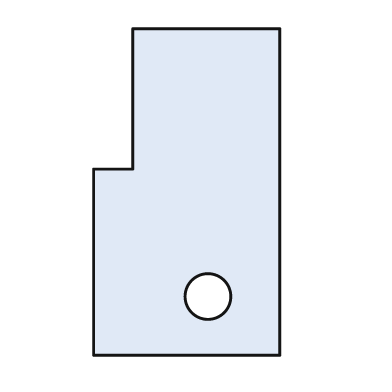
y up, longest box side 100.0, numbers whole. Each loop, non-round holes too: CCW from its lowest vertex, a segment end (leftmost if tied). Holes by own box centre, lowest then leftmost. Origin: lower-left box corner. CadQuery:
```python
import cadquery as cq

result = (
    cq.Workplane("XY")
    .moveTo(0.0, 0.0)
    .lineTo(57.0, 0.0)
    .lineTo(57.0, 100.0)
    .lineTo(12.0, 100.0)
    .lineTo(12.0, 57.0)
    .lineTo(0.0, 57.0)
    .close()
    .moveTo(35.0, 18.0)
    .circle(7.0)
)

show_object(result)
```